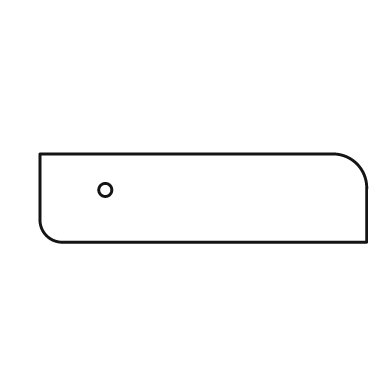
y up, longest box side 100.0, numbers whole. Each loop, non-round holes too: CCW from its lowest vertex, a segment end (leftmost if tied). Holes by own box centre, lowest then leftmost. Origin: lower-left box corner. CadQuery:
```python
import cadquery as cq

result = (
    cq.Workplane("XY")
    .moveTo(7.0, 0.0)
    .lineTo(100.0, 0.0)
    .lineTo(100.0, 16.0)
    .threePointArc((97.0, 24.0), (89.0, 27.0))
    .lineTo(0.0, 27.0)
    .lineTo(0.0, 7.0)
    .threePointArc((2.0, 2.0), (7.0, 0.0))
    .close()
    .moveTo(20.0, 16.0)
    .circle(2.0)
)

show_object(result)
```